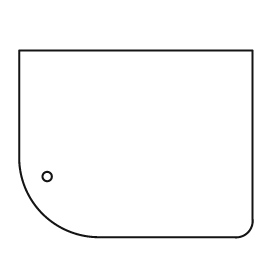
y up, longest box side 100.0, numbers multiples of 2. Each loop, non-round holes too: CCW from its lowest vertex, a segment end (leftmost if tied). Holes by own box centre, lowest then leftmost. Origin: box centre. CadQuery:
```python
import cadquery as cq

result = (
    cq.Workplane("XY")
    .moveTo(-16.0, -40.0)
    .lineTo(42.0, -40.0)
    .threePointArc((48.0, -38.0), (50.0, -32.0))
    .lineTo(50.0, 40.0)
    .lineTo(-50.0, 40.0)
    .lineTo(-50.0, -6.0)
    .threePointArc((-40.0, -30.0), (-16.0, -40.0))
    .close()
    .moveTo(-38.0, -14.0)
    .circle(2.0)
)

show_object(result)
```